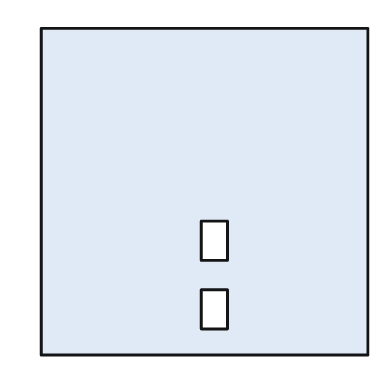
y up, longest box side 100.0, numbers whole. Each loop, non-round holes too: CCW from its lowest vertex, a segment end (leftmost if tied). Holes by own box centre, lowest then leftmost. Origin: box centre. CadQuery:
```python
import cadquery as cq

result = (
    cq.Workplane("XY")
    .moveTo(-50.0, -50.0)
    .lineTo(50.0, -50.0)
    .lineTo(50.0, 50.0)
    .lineTo(-50.0, 50.0)
    .close()
    .moveTo(-1.0, -42.0)
    .lineTo(7.0, -42.0)
    .lineTo(7.0, -30.0)
    .lineTo(-1.0, -30.0)
    .close()
    .moveTo(-1.0, -21.0)
    .lineTo(7.0, -21.0)
    .lineTo(7.0, -9.0)
    .lineTo(-1.0, -9.0)
    .close()
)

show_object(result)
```